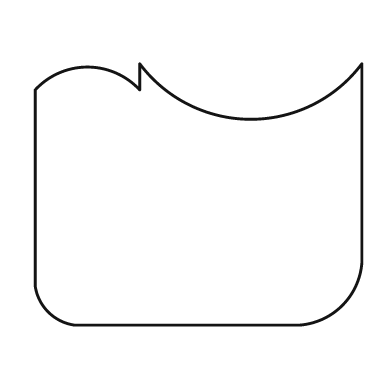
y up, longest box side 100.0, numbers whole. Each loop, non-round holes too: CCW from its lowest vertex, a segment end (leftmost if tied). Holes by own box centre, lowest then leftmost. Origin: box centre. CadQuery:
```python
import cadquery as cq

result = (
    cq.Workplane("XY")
    .moveTo(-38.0, -40.0)
    .lineTo(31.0, -40.0)
    .threePointArc((44.0, -34.0), (50.0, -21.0))
    .lineTo(50.0, 40.0)
    .threePointArc((16.0, 23.0), (-18.0, 40.0))
    .lineTo(-18.0, 32.0)
    .threePointArc((-34.0, 39.0), (-50.0, 32.0))
    .lineTo(-50.0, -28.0)
    .threePointArc((-46.0, -36.0), (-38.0, -40.0))
    .close()
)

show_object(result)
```